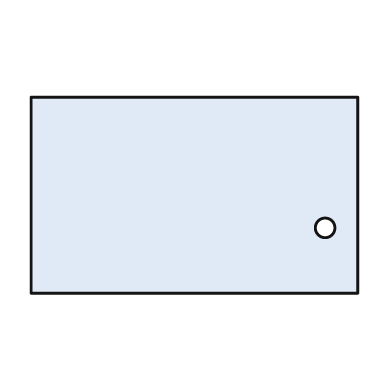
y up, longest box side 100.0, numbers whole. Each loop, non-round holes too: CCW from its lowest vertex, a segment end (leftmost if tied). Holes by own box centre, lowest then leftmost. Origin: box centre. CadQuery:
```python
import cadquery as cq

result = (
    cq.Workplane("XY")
    .moveTo(-50.0, -30.0)
    .lineTo(50.0, -30.0)
    .lineTo(50.0, 30.0)
    .lineTo(-50.0, 30.0)
    .close()
    .moveTo(40.0, -10.0)
    .circle(3.0)
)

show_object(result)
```